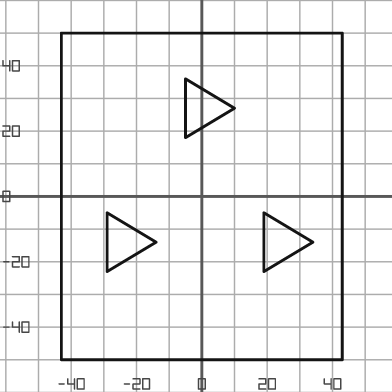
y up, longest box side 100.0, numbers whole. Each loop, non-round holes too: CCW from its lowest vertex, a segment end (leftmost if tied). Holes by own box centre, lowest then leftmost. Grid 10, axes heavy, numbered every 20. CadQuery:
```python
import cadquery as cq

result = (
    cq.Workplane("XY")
    .moveTo(-43.0, -50.0)
    .lineTo(43.0, -50.0)
    .lineTo(43.0, 50.0)
    .lineTo(-43.0, 50.0)
    .close()
    .moveTo(-29.0, -23.0)
    .lineTo(-14.0, -14.0)
    .lineTo(-29.0, -5.0)
    .close()
    .moveTo(19.0, -23.0)
    .lineTo(34.0, -14.0)
    .lineTo(19.0, -5.0)
    .close()
    .moveTo(-5.0, 18.0)
    .lineTo(10.0, 27.0)
    .lineTo(-5.0, 36.0)
    .close()
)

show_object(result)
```